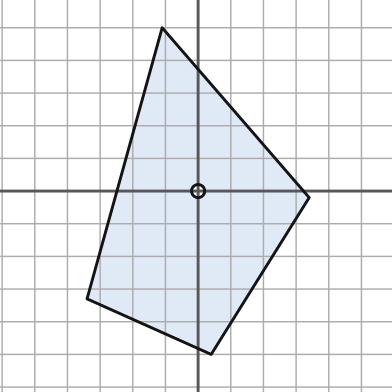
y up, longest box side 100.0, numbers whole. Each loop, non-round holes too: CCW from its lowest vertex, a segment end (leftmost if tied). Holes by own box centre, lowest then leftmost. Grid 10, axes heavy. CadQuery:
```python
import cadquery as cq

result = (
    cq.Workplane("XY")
    .moveTo(4.0, -50.0)
    .lineTo(34.0, -2.0)
    .lineTo(-11.0, 50.0)
    .lineTo(-34.0, -33.0)
    .close()
    .moveTo(0.0, 0.0)
    .circle(2.0)
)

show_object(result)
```